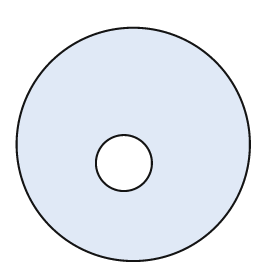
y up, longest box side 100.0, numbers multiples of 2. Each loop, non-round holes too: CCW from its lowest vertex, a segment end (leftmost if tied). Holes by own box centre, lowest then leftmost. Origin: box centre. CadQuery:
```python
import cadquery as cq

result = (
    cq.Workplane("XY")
    .moveTo(0.0, 0.0)
    .circle(50.0)
    .moveTo(-4.0, -8.0)
    .circle(12.0)
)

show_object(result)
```